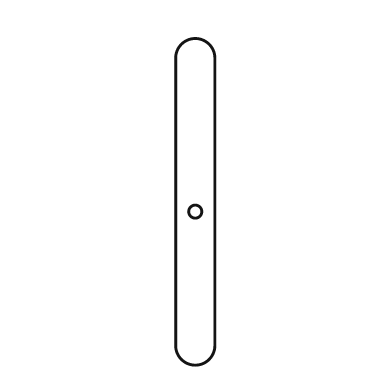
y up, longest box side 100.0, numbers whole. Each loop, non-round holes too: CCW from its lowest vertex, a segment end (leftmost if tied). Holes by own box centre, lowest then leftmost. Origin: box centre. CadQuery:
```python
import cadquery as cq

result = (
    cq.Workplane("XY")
    .moveTo(-6.0, -44.0)
    .threePointArc((0.0, -50.0), (6.0, -44.0))
    .lineTo(6.0, 44.0)
    .threePointArc((0.0, 50.0), (-6.0, 44.0))
    .close()
    .moveTo(0.0, -3.0)
    .circle(2.0)
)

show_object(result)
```